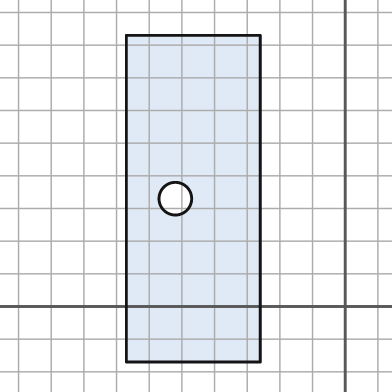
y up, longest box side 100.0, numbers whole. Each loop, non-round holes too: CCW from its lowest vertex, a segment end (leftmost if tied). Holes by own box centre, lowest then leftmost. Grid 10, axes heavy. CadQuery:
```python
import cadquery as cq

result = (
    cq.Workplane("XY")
    .moveTo(-67.0, -17.0)
    .lineTo(-26.0, -17.0)
    .lineTo(-26.0, 83.0)
    .lineTo(-67.0, 83.0)
    .close()
    .moveTo(-52.0, 33.0)
    .circle(5.0)
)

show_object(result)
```